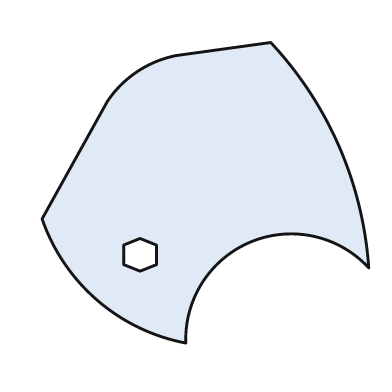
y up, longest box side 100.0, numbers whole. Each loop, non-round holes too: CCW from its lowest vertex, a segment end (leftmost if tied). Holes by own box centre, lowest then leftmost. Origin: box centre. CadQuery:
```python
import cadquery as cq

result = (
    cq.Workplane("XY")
    .moveTo(-6.0, -46.0)
    .threePointArc((14.0, -15.0), (50.0, -23.0))
    .threePointArc((41.0, 14.0), (20.0, 46.0))
    .lineTo(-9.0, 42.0)
    .threePointArc((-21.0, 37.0), (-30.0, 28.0))
    .lineTo(-50.0, -8.0)
    .threePointArc((-33.0, -33.0), (-6.0, -46.0))
    .close()
    .moveTo(-20.0, -24.0)
    .lineTo(-15.0, -22.0)
    .lineTo(-15.0, -16.0)
    .lineTo(-20.0, -14.0)
    .lineTo(-25.0, -16.0)
    .lineTo(-25.0, -22.0)
    .close()
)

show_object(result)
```